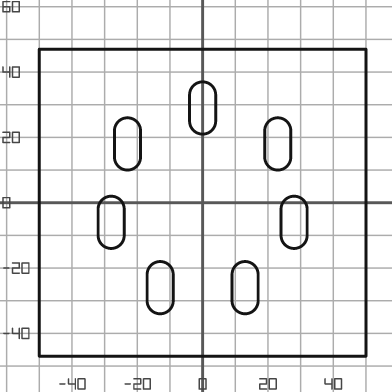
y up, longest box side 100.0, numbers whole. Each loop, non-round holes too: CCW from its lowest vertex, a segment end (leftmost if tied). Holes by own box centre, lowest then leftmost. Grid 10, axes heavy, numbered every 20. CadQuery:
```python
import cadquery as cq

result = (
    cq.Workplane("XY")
    .moveTo(-50.0, -47.0)
    .lineTo(50.0, -47.0)
    .lineTo(50.0, 47.0)
    .lineTo(-50.0, 47.0)
    .close()
    .moveTo(-17.0, -30.0)
    .threePointArc((-13.0, -34.0), (-9.0, -30.0))
    .lineTo(-9.0, -22.0)
    .threePointArc((-13.0, -18.0), (-17.0, -22.0))
    .close()
    .moveTo(9.0, -30.0)
    .threePointArc((13.0, -34.0), (17.0, -30.0))
    .lineTo(17.0, -22.0)
    .threePointArc((13.0, -18.0), (9.0, -22.0))
    .close()
    .moveTo(-32.0, -10.0)
    .threePointArc((-28.0, -14.0), (-24.0, -10.0))
    .lineTo(-24.0, -2.0)
    .threePointArc((-28.0, 2.0), (-32.0, -2.0))
    .close()
    .moveTo(24.0, -10.0)
    .threePointArc((28.0, -14.0), (32.0, -10.0))
    .lineTo(32.0, -2.0)
    .threePointArc((28.0, 2.0), (24.0, -2.0))
    .close()
    .moveTo(-27.0, 14.0)
    .threePointArc((-23.0, 10.0), (-19.0, 14.0))
    .lineTo(-19.0, 22.0)
    .threePointArc((-23.0, 26.0), (-27.0, 22.0))
    .close()
    .moveTo(19.0, 14.0)
    .threePointArc((23.0, 10.0), (27.0, 14.0))
    .lineTo(27.0, 22.0)
    .threePointArc((23.0, 26.0), (19.0, 22.0))
    .close()
    .moveTo(-4.0, 25.0)
    .threePointArc((0.0, 21.0), (4.0, 25.0))
    .lineTo(4.0, 33.0)
    .threePointArc((0.0, 37.0), (-4.0, 33.0))
    .close()
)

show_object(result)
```